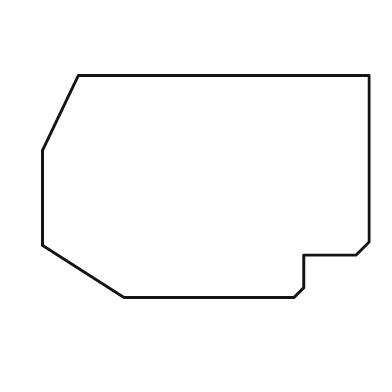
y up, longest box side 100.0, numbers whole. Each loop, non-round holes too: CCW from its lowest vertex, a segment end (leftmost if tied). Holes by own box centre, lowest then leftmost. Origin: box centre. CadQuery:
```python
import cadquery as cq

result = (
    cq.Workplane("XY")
    .moveTo(-25.0, -34.0)
    .lineTo(27.0, -34.0)
    .lineTo(30.0, -31.0)
    .lineTo(30.0, -21.0)
    .lineTo(46.0, -21.0)
    .lineTo(50.0, -17.0)
    .lineTo(50.0, 34.0)
    .lineTo(-39.0, 34.0)
    .lineTo(-50.0, 11.0)
    .lineTo(-50.0, -18.0)
    .close()
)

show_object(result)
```